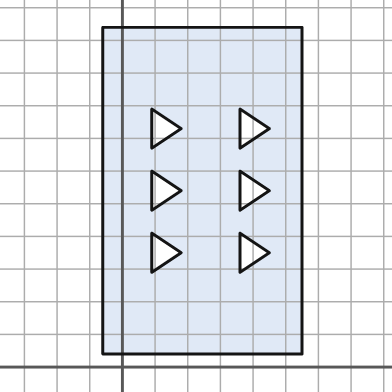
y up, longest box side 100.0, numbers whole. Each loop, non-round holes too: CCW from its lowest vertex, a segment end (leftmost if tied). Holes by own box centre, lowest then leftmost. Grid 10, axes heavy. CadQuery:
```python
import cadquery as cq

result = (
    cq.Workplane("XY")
    .moveTo(-6.0, 4.0)
    .lineTo(55.0, 4.0)
    .lineTo(55.0, 104.0)
    .lineTo(-6.0, 104.0)
    .close()
    .moveTo(9.0, 29.0)
    .lineTo(18.0, 35.0)
    .lineTo(9.0, 41.0)
    .close()
    .moveTo(36.0, 29.0)
    .lineTo(45.0, 35.0)
    .lineTo(36.0, 41.0)
    .close()
    .moveTo(9.0, 48.0)
    .lineTo(18.0, 54.0)
    .lineTo(9.0, 60.0)
    .close()
    .moveTo(36.0, 48.0)
    .lineTo(45.0, 54.0)
    .lineTo(36.0, 60.0)
    .close()
    .moveTo(9.0, 67.0)
    .lineTo(18.0, 73.0)
    .lineTo(9.0, 79.0)
    .close()
    .moveTo(36.0, 67.0)
    .lineTo(45.0, 73.0)
    .lineTo(36.0, 79.0)
    .close()
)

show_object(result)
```